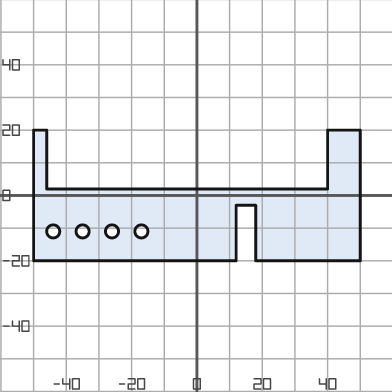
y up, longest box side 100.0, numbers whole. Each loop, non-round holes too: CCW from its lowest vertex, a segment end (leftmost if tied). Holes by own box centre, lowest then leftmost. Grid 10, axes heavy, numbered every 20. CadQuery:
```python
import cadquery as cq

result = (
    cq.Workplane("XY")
    .moveTo(-50.0, -20.0)
    .lineTo(12.0, -20.0)
    .lineTo(12.0, -3.0)
    .lineTo(18.0, -3.0)
    .lineTo(18.0, -20.0)
    .lineTo(50.0, -20.0)
    .lineTo(50.0, 20.0)
    .lineTo(40.0, 20.0)
    .lineTo(40.0, 2.0)
    .lineTo(-46.0, 2.0)
    .lineTo(-46.0, 20.0)
    .lineTo(-50.0, 20.0)
    .close()
    .moveTo(-44.0, -11.0)
    .circle(2.0)
    .moveTo(-35.0, -11.0)
    .circle(2.0)
    .moveTo(-26.0, -11.0)
    .circle(2.0)
    .moveTo(-17.0, -11.0)
    .circle(2.0)
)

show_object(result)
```